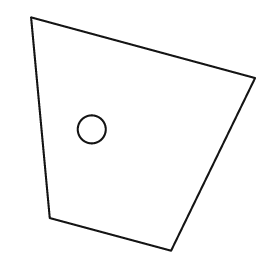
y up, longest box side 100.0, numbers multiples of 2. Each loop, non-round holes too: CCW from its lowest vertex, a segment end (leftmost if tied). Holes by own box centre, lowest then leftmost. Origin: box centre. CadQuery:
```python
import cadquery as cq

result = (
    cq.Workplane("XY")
    .moveTo(12.0, -50.0)
    .lineTo(48.0, 24.0)
    .lineTo(-48.0, 50.0)
    .lineTo(-40.0, -36.0)
    .close()
    .moveTo(-22.0, 2.0)
    .circle(6.0)
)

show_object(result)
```